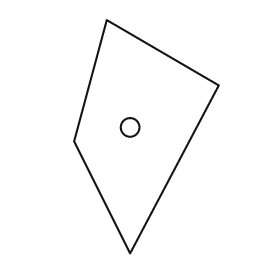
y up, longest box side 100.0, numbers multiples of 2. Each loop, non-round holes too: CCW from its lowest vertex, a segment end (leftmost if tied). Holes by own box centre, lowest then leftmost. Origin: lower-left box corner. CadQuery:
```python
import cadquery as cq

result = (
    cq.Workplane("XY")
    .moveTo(24.0, 0.0)
    .lineTo(62.0, 72.0)
    .lineTo(14.0, 100.0)
    .lineTo(0.0, 48.0)
    .close()
    .moveTo(24.0, 54.0)
    .circle(4.0)
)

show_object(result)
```